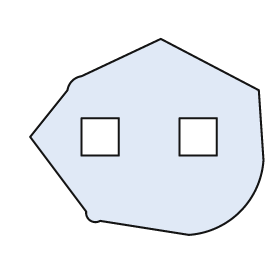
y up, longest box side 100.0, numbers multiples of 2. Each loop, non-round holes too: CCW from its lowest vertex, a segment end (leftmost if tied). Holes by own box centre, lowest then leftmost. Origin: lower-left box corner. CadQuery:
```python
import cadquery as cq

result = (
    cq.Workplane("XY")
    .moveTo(68.0, 0.0)
    .threePointArc((90.0, 10.0), (100.0, 32.0))
    .lineTo(98.0, 62.0)
    .lineTo(56.0, 84.0)
    .lineTo(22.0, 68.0)
    .threePointArc((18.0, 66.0), (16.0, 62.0))
    .lineTo(0.0, 42.0)
    .lineTo(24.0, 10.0)
    .threePointArc((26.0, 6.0), (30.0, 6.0))
    .close()
    .moveTo(22.0, 34.0)
    .lineTo(38.0, 34.0)
    .lineTo(38.0, 50.0)
    .lineTo(22.0, 50.0)
    .close()
    .moveTo(64.0, 34.0)
    .lineTo(80.0, 34.0)
    .lineTo(80.0, 50.0)
    .lineTo(64.0, 50.0)
    .close()
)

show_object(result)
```